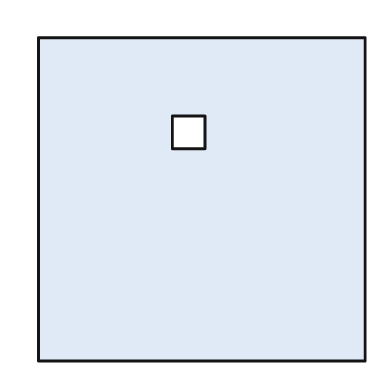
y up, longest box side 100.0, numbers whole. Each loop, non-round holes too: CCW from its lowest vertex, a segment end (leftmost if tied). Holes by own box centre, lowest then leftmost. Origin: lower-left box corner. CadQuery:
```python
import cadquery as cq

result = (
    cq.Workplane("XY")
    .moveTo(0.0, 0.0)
    .lineTo(100.0, 0.0)
    .lineTo(100.0, 99.0)
    .lineTo(0.0, 99.0)
    .close()
    .moveTo(41.0, 65.0)
    .lineTo(51.0, 65.0)
    .lineTo(51.0, 75.0)
    .lineTo(41.0, 75.0)
    .close()
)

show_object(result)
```